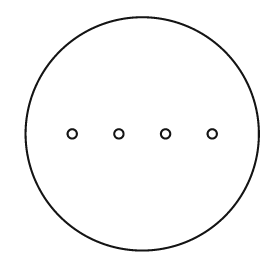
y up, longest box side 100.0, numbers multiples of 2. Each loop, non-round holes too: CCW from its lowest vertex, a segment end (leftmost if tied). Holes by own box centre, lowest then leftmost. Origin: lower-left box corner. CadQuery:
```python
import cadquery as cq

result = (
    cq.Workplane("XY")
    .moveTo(50.0, 50.0)
    .circle(50.0)
    .moveTo(20.0, 50.0)
    .circle(2.0)
    .moveTo(40.0, 50.0)
    .circle(2.0)
    .moveTo(60.0, 50.0)
    .circle(2.0)
    .moveTo(80.0, 50.0)
    .circle(2.0)
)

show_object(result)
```